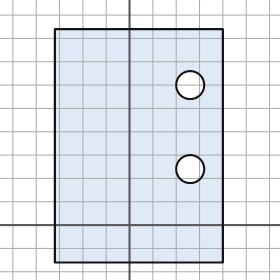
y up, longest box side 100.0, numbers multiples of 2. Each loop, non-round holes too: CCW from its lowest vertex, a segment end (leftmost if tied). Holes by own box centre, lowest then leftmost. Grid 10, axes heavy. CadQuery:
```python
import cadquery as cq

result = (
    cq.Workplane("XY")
    .moveTo(-32.0, -16.0)
    .lineTo(40.0, -16.0)
    .lineTo(40.0, 84.0)
    .lineTo(-32.0, 84.0)
    .close()
    .moveTo(26.0, 24.0)
    .circle(6.0)
    .moveTo(26.0, 60.0)
    .circle(6.0)
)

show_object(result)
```